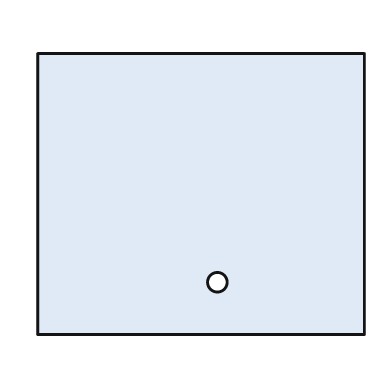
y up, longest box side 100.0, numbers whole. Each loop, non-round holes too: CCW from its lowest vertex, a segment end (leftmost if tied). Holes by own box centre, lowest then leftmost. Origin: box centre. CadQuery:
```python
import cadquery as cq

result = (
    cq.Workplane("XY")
    .moveTo(-50.0, -43.0)
    .lineTo(50.0, -43.0)
    .lineTo(50.0, 43.0)
    .lineTo(-50.0, 43.0)
    .close()
    .moveTo(5.0, -27.0)
    .circle(3.0)
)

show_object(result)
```